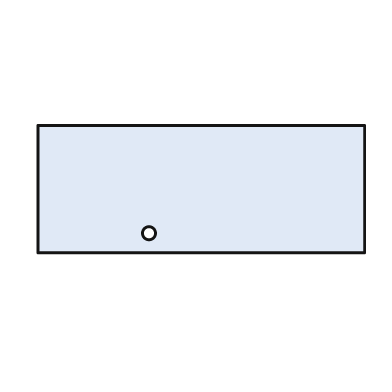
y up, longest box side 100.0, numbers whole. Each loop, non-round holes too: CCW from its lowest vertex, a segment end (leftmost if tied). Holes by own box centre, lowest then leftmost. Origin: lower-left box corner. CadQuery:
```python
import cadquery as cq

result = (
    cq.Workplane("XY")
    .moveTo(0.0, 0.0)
    .lineTo(100.0, 0.0)
    .lineTo(100.0, 39.0)
    .lineTo(0.0, 39.0)
    .close()
    .moveTo(34.0, 6.0)
    .circle(2.0)
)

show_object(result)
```